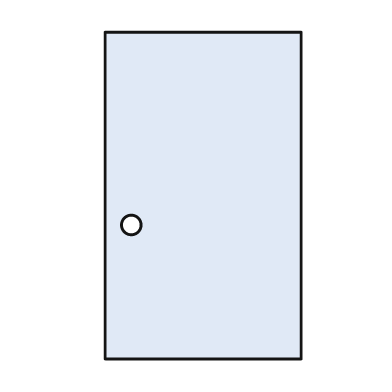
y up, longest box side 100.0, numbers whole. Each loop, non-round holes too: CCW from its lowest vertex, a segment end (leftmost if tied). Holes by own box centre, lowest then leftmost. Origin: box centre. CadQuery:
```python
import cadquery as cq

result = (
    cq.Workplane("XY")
    .moveTo(-30.0, -50.0)
    .lineTo(30.0, -50.0)
    .lineTo(30.0, 50.0)
    .lineTo(-30.0, 50.0)
    .close()
    .moveTo(-22.0, -9.0)
    .circle(3.0)
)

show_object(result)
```